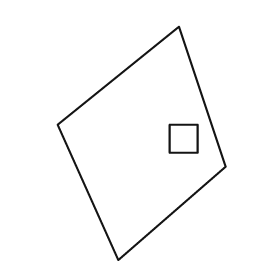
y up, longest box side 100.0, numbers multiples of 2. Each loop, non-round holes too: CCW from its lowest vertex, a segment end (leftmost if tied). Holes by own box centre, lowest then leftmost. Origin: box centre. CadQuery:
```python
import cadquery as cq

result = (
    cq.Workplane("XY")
    .moveTo(-10.0, -50.0)
    .lineTo(36.0, -10.0)
    .lineTo(16.0, 50.0)
    .lineTo(-36.0, 8.0)
    .close()
    .moveTo(12.0, -4.0)
    .lineTo(24.0, -4.0)
    .lineTo(24.0, 8.0)
    .lineTo(12.0, 8.0)
    .close()
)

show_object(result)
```